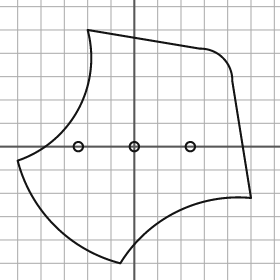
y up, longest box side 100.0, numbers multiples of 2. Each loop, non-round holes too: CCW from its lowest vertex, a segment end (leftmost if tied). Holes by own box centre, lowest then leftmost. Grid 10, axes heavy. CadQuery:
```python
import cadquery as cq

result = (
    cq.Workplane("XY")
    .moveTo(-6.0, -50.0)
    .threePointArc((18.0, -28.0), (50.0, -22.0))
    .lineTo(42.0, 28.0)
    .threePointArc((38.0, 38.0), (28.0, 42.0))
    .lineTo(-20.0, 50.0)
    .threePointArc((-24.0, 16.0), (-50.0, -6.0))
    .threePointArc((-34.0, -34.0), (-6.0, -50.0))
    .close()
    .moveTo(-24.0, 0.0)
    .circle(2.0)
    .moveTo(0.0, 0.0)
    .circle(2.0)
    .moveTo(24.0, 0.0)
    .circle(2.0)
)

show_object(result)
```